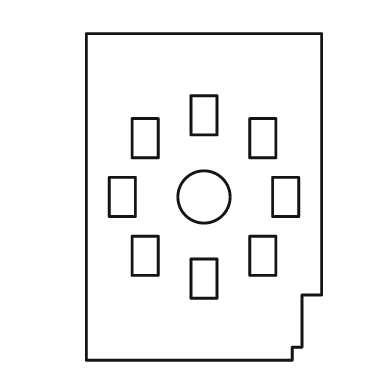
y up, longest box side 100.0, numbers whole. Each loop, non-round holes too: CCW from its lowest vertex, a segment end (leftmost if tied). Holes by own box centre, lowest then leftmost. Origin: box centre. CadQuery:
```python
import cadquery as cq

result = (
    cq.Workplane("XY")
    .moveTo(-36.0, -50.0)
    .lineTo(27.0, -50.0)
    .lineTo(27.0, -46.0)
    .lineTo(30.0, -46.0)
    .lineTo(30.0, -30.0)
    .lineTo(36.0, -30.0)
    .lineTo(36.0, 50.0)
    .lineTo(-36.0, 50.0)
    .close()
    .moveTo(-4.0, -31.0)
    .lineTo(4.0, -31.0)
    .lineTo(4.0, -19.0)
    .lineTo(-4.0, -19.0)
    .close()
    .moveTo(-22.0, -24.0)
    .lineTo(-14.0, -24.0)
    .lineTo(-14.0, -12.0)
    .lineTo(-22.0, -12.0)
    .close()
    .moveTo(14.0, -24.0)
    .lineTo(22.0, -24.0)
    .lineTo(22.0, -12.0)
    .lineTo(14.0, -12.0)
    .close()
    .moveTo(-29.0, -6.0)
    .lineTo(-21.0, -6.0)
    .lineTo(-21.0, 6.0)
    .lineTo(-29.0, 6.0)
    .close()
    .moveTo(0.0, 0.0)
    .circle(8.0)
    .moveTo(21.0, -6.0)
    .lineTo(29.0, -6.0)
    .lineTo(29.0, 6.0)
    .lineTo(21.0, 6.0)
    .close()
    .moveTo(-22.0, 12.0)
    .lineTo(-14.0, 12.0)
    .lineTo(-14.0, 24.0)
    .lineTo(-22.0, 24.0)
    .close()
    .moveTo(14.0, 12.0)
    .lineTo(22.0, 12.0)
    .lineTo(22.0, 24.0)
    .lineTo(14.0, 24.0)
    .close()
    .moveTo(-4.0, 19.0)
    .lineTo(4.0, 19.0)
    .lineTo(4.0, 31.0)
    .lineTo(-4.0, 31.0)
    .close()
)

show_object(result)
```